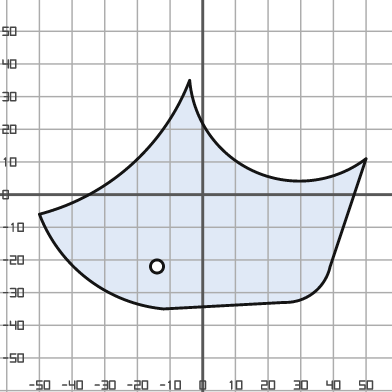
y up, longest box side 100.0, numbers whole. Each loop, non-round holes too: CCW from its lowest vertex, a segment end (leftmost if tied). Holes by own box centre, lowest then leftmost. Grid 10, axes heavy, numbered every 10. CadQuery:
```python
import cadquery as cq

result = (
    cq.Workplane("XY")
    .moveTo(-12.0, -35.0)
    .lineTo(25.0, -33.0)
    .threePointArc((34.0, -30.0), (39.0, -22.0))
    .lineTo(50.0, 11.0)
    .threePointArc((16.0, 7.0), (-4.0, 35.0))
    .threePointArc((-22.0, 9.0), (-50.0, -6.0))
    .threePointArc((-35.0, -26.0), (-12.0, -35.0))
    .close()
    .moveTo(-14.0, -22.0)
    .circle(2.0)
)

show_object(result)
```